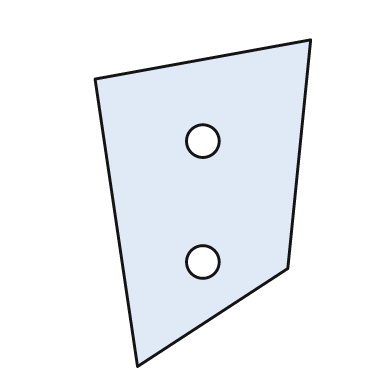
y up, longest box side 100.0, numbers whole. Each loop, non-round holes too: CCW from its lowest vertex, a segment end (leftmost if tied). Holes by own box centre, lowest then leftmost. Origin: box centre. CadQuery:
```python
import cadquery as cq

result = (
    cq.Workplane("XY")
    .moveTo(-20.0, -50.0)
    .lineTo(26.0, -20.0)
    .lineTo(33.0, 50.0)
    .lineTo(-33.0, 38.0)
    .close()
    .moveTo(0.0, -18.0)
    .circle(5.0)
    .moveTo(0.0, 19.0)
    .circle(5.0)
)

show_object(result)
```